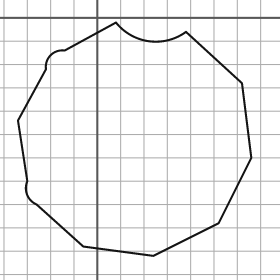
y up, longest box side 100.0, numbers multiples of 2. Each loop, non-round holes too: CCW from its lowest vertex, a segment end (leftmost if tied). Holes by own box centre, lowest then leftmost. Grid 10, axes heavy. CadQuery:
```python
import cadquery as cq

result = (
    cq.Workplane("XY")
    .moveTo(24.0, -102.0)
    .lineTo(52.0, -88.0)
    .lineTo(66.0, -60.0)
    .lineTo(62.0, -28.0)
    .lineTo(38.0, -6.0)
    .threePointArc((22.0, -10.0), (8.0, -2.0))
    .lineTo(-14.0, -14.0)
    .threePointArc((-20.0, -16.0), (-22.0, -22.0))
    .lineTo(-34.0, -44.0)
    .lineTo(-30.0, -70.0)
    .threePointArc((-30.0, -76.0), (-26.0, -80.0))
    .lineTo(-6.0, -98.0)
    .close()
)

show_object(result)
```